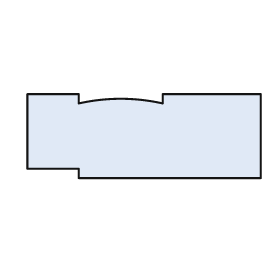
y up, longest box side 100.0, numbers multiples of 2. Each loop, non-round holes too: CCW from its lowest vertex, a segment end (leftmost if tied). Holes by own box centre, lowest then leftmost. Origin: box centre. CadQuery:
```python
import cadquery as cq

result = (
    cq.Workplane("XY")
    .moveTo(-28.0, -18.0)
    .lineTo(50.0, -18.0)
    .lineTo(50.0, 18.0)
    .lineTo(8.0, 18.0)
    .lineTo(8.0, 14.0)
    .threePointArc((-10.0, 16.0), (-28.0, 14.0))
    .lineTo(-28.0, 18.0)
    .lineTo(-50.0, 18.0)
    .lineTo(-50.0, -14.0)
    .lineTo(-28.0, -14.0)
    .close()
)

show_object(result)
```